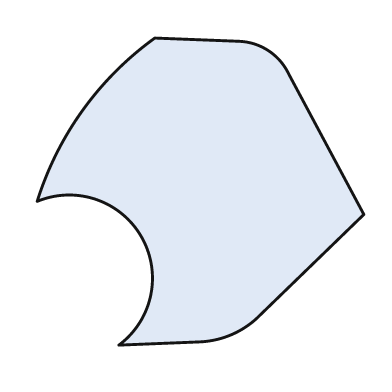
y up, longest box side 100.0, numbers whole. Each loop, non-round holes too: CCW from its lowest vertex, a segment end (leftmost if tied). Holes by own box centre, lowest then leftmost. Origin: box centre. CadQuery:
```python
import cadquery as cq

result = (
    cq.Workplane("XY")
    .moveTo(-25.0, -47.0)
    .lineTo(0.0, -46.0)
    .threePointArc((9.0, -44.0), (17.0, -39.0))
    .lineTo(50.0, -7.0)
    .lineTo(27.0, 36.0)
    .threePointArc((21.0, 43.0), (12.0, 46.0))
    .lineTo(-14.0, 47.0)
    .threePointArc((-36.0, 25.0), (-50.0, -3.0))
    .threePointArc((-18.0, -14.0), (-25.0, -47.0))
    .close()
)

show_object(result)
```